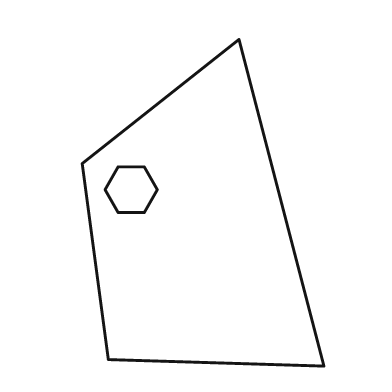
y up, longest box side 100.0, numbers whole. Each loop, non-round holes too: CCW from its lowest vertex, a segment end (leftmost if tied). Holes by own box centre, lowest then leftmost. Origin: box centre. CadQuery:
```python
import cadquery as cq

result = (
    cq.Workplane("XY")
    .moveTo(37.0, -50.0)
    .lineTo(11.0, 50.0)
    .lineTo(-37.0, 12.0)
    .lineTo(-29.0, -48.0)
    .close()
    .moveTo(-26.0, -3.0)
    .lineTo(-18.0, -3.0)
    .lineTo(-14.0, 4.0)
    .lineTo(-18.0, 11.0)
    .lineTo(-26.0, 11.0)
    .lineTo(-30.0, 4.0)
    .close()
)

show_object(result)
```